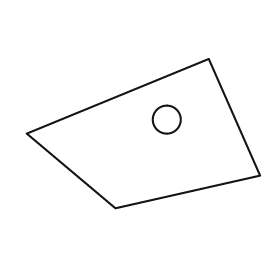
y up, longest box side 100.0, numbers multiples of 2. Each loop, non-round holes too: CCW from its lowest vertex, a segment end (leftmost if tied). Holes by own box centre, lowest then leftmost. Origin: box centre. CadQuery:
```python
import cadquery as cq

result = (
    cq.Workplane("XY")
    .moveTo(-12.0, -32.0)
    .lineTo(50.0, -18.0)
    .lineTo(28.0, 32.0)
    .lineTo(-50.0, 0.0)
    .close()
    .moveTo(10.0, 6.0)
    .circle(6.0)
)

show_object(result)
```